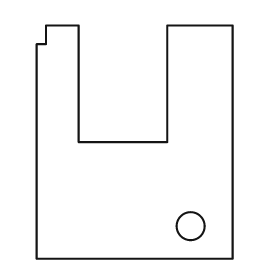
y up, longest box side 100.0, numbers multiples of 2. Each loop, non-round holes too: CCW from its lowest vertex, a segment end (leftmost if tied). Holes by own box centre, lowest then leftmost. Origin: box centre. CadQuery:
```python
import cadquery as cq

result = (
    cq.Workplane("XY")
    .moveTo(-42.0, -50.0)
    .lineTo(42.0, -50.0)
    .lineTo(42.0, 50.0)
    .lineTo(14.0, 50.0)
    .lineTo(14.0, 0.0)
    .lineTo(-24.0, 0.0)
    .lineTo(-24.0, 50.0)
    .lineTo(-38.0, 50.0)
    .lineTo(-38.0, 42.0)
    .lineTo(-42.0, 42.0)
    .close()
    .moveTo(24.0, -36.0)
    .circle(6.0)
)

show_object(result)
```